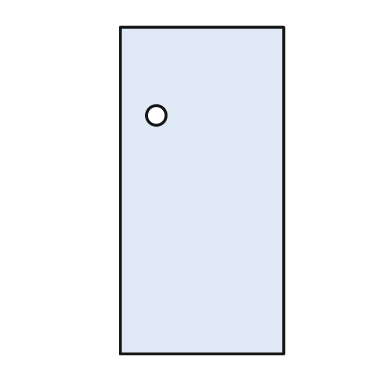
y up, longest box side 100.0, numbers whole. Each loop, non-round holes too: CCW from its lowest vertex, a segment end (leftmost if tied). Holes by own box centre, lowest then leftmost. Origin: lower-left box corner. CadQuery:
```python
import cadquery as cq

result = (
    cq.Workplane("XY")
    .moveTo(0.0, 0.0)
    .lineTo(50.0, 0.0)
    .lineTo(50.0, 100.0)
    .lineTo(0.0, 100.0)
    .close()
    .moveTo(11.0, 73.0)
    .circle(3.0)
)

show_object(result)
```